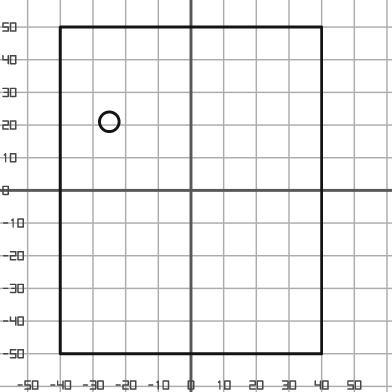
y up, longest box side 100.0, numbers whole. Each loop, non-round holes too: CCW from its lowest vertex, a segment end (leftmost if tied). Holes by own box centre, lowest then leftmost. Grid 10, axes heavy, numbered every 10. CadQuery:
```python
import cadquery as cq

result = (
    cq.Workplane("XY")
    .moveTo(-40.0, -50.0)
    .lineTo(40.0, -50.0)
    .lineTo(40.0, 50.0)
    .lineTo(-40.0, 50.0)
    .close()
    .moveTo(-25.0, 21.0)
    .circle(3.0)
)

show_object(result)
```